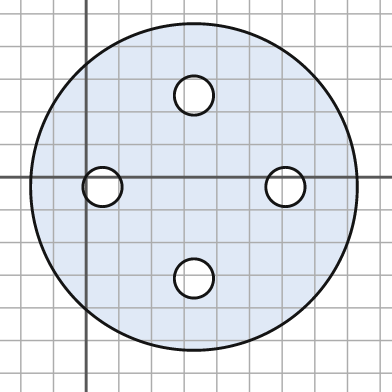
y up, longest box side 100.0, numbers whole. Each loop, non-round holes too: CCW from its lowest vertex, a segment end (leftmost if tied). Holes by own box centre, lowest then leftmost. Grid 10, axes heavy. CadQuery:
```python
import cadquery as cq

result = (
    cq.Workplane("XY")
    .moveTo(33.0, -3.0)
    .circle(50.0)
    .moveTo(33.0, -31.0)
    .circle(6.0)
    .moveTo(5.0, -3.0)
    .circle(6.0)
    .moveTo(61.0, -3.0)
    .circle(6.0)
    .moveTo(33.0, 25.0)
    .circle(6.0)
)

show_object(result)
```